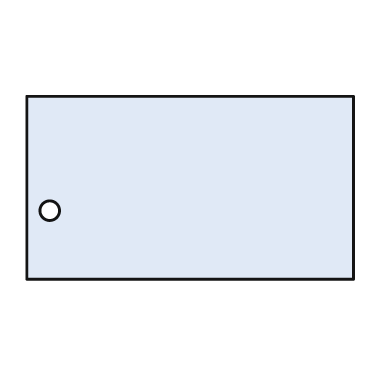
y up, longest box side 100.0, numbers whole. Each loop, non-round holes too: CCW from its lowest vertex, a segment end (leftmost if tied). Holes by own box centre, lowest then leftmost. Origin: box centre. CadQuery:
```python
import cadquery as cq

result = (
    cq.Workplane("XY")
    .moveTo(-50.0, -28.0)
    .lineTo(50.0, -28.0)
    .lineTo(50.0, 28.0)
    .lineTo(-50.0, 28.0)
    .close()
    .moveTo(-43.0, -7.0)
    .circle(3.0)
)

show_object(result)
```